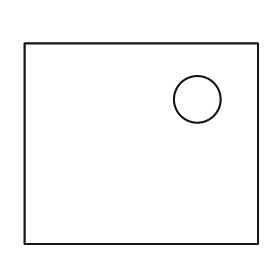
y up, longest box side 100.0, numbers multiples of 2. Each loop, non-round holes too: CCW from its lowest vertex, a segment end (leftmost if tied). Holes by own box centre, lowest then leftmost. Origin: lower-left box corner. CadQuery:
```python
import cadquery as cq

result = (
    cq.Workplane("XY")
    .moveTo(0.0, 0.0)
    .lineTo(100.0, 0.0)
    .lineTo(100.0, 86.0)
    .lineTo(0.0, 86.0)
    .close()
    .moveTo(74.0, 62.0)
    .circle(10.0)
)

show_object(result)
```